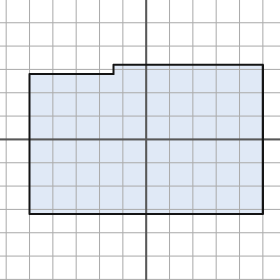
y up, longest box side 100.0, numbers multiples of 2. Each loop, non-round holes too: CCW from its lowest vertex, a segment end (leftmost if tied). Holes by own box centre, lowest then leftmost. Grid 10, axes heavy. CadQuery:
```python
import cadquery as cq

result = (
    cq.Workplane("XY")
    .moveTo(-50.0, -32.0)
    .lineTo(50.0, -32.0)
    .lineTo(50.0, 32.0)
    .lineTo(-14.0, 32.0)
    .lineTo(-14.0, 28.0)
    .lineTo(-50.0, 28.0)
    .close()
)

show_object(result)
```